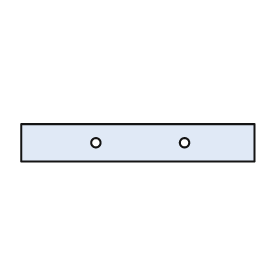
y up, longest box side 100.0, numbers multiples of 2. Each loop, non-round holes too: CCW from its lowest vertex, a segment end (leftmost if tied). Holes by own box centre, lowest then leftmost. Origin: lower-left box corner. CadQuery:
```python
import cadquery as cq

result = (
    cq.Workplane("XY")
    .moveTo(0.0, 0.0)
    .lineTo(100.0, 0.0)
    .lineTo(100.0, 16.0)
    .lineTo(0.0, 16.0)
    .close()
    .moveTo(32.0, 8.0)
    .circle(2.0)
    .moveTo(70.0, 8.0)
    .circle(2.0)
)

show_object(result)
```